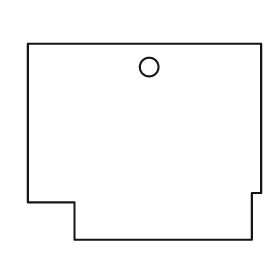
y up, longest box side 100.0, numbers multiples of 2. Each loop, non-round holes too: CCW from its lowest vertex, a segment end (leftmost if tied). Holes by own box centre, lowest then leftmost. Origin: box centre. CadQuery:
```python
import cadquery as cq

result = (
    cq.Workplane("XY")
    .moveTo(-30.0, -42.0)
    .lineTo(46.0, -42.0)
    .lineTo(46.0, -22.0)
    .lineTo(50.0, -22.0)
    .lineTo(50.0, 42.0)
    .lineTo(-50.0, 42.0)
    .lineTo(-50.0, -26.0)
    .lineTo(-30.0, -26.0)
    .close()
    .moveTo(2.0, 32.0)
    .circle(4.0)
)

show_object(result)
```